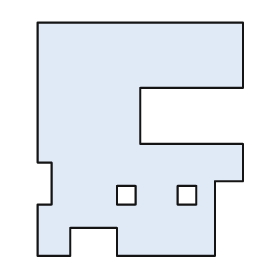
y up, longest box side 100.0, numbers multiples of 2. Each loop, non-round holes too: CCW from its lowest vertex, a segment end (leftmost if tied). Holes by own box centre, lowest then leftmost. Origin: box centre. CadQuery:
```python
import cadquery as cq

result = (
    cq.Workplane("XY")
    .moveTo(-44.0, -50.0)
    .lineTo(-30.0, -50.0)
    .lineTo(-30.0, -38.0)
    .lineTo(-10.0, -38.0)
    .lineTo(-10.0, -50.0)
    .lineTo(32.0, -50.0)
    .lineTo(32.0, -18.0)
    .lineTo(44.0, -18.0)
    .lineTo(44.0, -2.0)
    .lineTo(0.0, -2.0)
    .lineTo(0.0, 22.0)
    .lineTo(44.0, 22.0)
    .lineTo(44.0, 50.0)
    .lineTo(-44.0, 50.0)
    .lineTo(-44.0, -10.0)
    .lineTo(-38.0, -10.0)
    .lineTo(-38.0, -28.0)
    .lineTo(-44.0, -28.0)
    .close()
    .moveTo(-10.0, -28.0)
    .lineTo(-2.0, -28.0)
    .lineTo(-2.0, -20.0)
    .lineTo(-10.0, -20.0)
    .close()
    .moveTo(16.0, -28.0)
    .lineTo(24.0, -28.0)
    .lineTo(24.0, -20.0)
    .lineTo(16.0, -20.0)
    .close()
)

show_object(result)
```